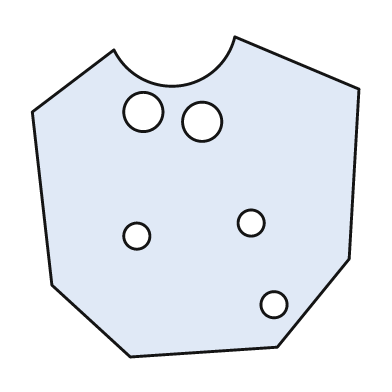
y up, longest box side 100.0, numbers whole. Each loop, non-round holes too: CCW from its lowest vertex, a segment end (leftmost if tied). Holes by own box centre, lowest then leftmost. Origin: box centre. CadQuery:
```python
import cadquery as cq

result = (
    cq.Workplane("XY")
    .moveTo(-20.0, -49.0)
    .lineTo(25.0, -46.0)
    .lineTo(47.0, -19.0)
    .lineTo(50.0, 33.0)
    .lineTo(12.0, 49.0)
    .threePointArc((-5.0, 34.0), (-25.0, 45.0))
    .lineTo(-50.0, 26.0)
    .lineTo(-44.0, -27.0)
    .close()
    .moveTo(24.0, -33.0)
    .circle(4.0)
    .moveTo(-18.0, -12.0)
    .circle(4.0)
    .moveTo(17.0, -8.0)
    .circle(4.0)
    .moveTo(2.0, 23.0)
    .circle(6.0)
    .moveTo(-16.0, 26.0)
    .circle(6.0)
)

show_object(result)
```